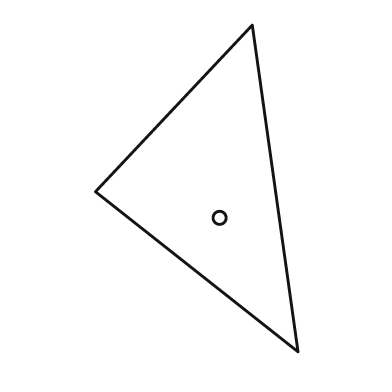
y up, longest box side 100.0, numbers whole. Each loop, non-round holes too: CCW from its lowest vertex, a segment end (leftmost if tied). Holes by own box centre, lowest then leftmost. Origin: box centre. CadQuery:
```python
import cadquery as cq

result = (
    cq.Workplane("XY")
    .moveTo(31.0, -50.0)
    .lineTo(17.0, 50.0)
    .lineTo(-31.0, -1.0)
    .close()
    .moveTo(7.0, -9.0)
    .circle(2.0)
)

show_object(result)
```